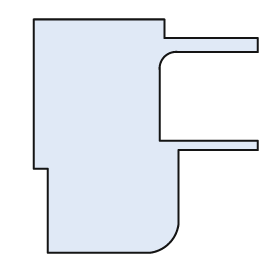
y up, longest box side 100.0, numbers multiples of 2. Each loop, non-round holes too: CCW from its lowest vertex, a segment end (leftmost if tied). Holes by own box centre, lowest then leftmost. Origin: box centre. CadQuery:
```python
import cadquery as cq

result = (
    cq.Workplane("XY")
    .moveTo(-42.0, -50.0)
    .lineTo(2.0, -50.0)
    .threePointArc((10.0, -46.0), (14.0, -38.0))
    .lineTo(14.0, -6.0)
    .lineTo(48.0, -6.0)
    .lineTo(48.0, -2.0)
    .lineTo(6.0, -2.0)
    .lineTo(6.0, 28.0)
    .threePointArc((8.0, 34.0), (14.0, 36.0))
    .lineTo(48.0, 36.0)
    .lineTo(48.0, 42.0)
    .lineTo(8.0, 42.0)
    .lineTo(8.0, 50.0)
    .lineTo(-48.0, 50.0)
    .lineTo(-48.0, -14.0)
    .lineTo(-42.0, -14.0)
    .close()
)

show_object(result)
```